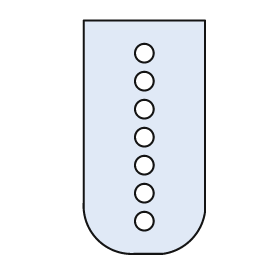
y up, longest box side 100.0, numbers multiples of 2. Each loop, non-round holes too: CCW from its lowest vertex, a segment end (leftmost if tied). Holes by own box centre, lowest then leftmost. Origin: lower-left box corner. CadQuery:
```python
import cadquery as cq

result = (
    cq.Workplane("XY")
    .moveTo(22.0, 0.0)
    .lineTo(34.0, 0.0)
    .threePointArc((46.0, 6.0), (52.0, 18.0))
    .lineTo(52.0, 100.0)
    .lineTo(0.0, 100.0)
    .lineTo(0.0, 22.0)
    .threePointArc((6.0, 6.0), (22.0, 0.0))
    .close()
    .moveTo(26.0, 14.0)
    .circle(4.0)
    .moveTo(26.0, 26.0)
    .circle(4.0)
    .moveTo(26.0, 38.0)
    .circle(4.0)
    .moveTo(26.0, 50.0)
    .circle(4.0)
    .moveTo(26.0, 62.0)
    .circle(4.0)
    .moveTo(26.0, 74.0)
    .circle(4.0)
    .moveTo(26.0, 86.0)
    .circle(4.0)
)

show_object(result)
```